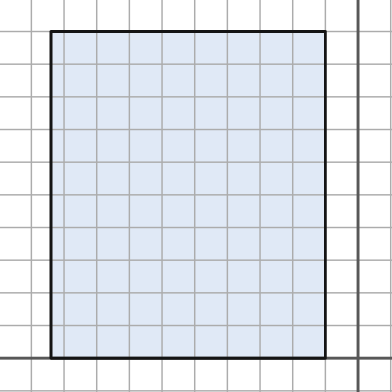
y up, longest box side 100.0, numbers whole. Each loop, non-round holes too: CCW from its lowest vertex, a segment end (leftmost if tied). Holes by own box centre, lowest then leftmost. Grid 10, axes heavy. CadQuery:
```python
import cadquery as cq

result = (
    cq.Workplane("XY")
    .moveTo(-94.0, 0.0)
    .lineTo(-10.0, 0.0)
    .lineTo(-10.0, 100.0)
    .lineTo(-94.0, 100.0)
    .close()
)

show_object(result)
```